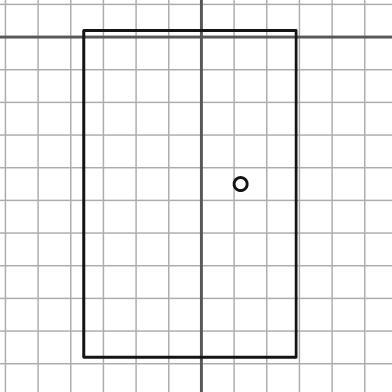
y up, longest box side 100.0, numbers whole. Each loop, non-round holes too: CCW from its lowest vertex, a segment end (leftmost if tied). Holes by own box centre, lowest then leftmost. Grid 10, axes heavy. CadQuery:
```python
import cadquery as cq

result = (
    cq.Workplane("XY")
    .moveTo(-36.0, -98.0)
    .lineTo(29.0, -98.0)
    .lineTo(29.0, 2.0)
    .lineTo(-36.0, 2.0)
    .close()
    .moveTo(12.0, -45.0)
    .circle(2.0)
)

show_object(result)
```